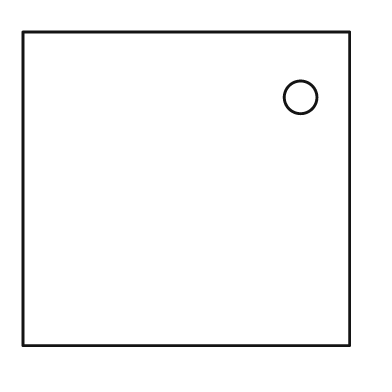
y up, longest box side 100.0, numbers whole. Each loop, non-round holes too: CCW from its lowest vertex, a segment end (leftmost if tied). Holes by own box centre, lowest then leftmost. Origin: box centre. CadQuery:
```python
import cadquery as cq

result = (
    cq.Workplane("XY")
    .moveTo(-50.0, -48.0)
    .lineTo(50.0, -48.0)
    .lineTo(50.0, 48.0)
    .lineTo(-50.0, 48.0)
    .close()
    .moveTo(35.0, 28.0)
    .circle(5.0)
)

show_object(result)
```